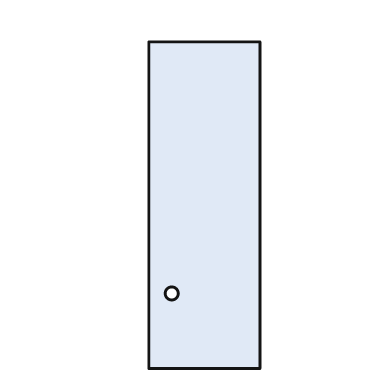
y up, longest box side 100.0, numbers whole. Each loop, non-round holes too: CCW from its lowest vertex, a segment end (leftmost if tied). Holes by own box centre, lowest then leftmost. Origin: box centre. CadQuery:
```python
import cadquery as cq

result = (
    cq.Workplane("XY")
    .moveTo(-17.0, -50.0)
    .lineTo(17.0, -50.0)
    .lineTo(17.0, 50.0)
    .lineTo(-17.0, 50.0)
    .close()
    .moveTo(-10.0, -27.0)
    .circle(2.0)
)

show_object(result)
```